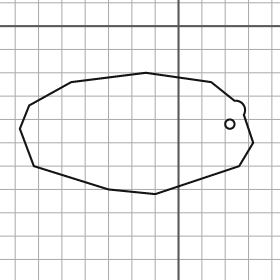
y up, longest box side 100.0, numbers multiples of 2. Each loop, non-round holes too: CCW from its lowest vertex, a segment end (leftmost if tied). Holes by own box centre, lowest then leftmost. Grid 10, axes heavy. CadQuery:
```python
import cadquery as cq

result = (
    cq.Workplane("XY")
    .moveTo(-10.0, -72.0)
    .lineTo(26.0, -60.0)
    .lineTo(32.0, -50.0)
    .lineTo(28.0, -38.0)
    .threePointArc((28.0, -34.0), (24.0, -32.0))
    .lineTo(14.0, -24.0)
    .lineTo(-14.0, -20.0)
    .lineTo(-46.0, -24.0)
    .lineTo(-64.0, -34.0)
    .lineTo(-68.0, -44.0)
    .lineTo(-62.0, -60.0)
    .lineTo(-30.0, -70.0)
    .close()
    .moveTo(22.0, -42.0)
    .circle(2.0)
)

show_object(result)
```